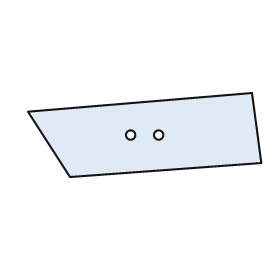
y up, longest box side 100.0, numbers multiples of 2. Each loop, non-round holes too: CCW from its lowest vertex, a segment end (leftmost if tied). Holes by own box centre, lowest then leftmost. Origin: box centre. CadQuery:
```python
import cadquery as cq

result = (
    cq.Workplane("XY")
    .moveTo(-32.0, -18.0)
    .lineTo(50.0, -12.0)
    .lineTo(46.0, 18.0)
    .lineTo(-50.0, 10.0)
    .close()
    .moveTo(-6.0, 0.0)
    .circle(2.0)
    .moveTo(6.0, 0.0)
    .circle(2.0)
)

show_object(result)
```